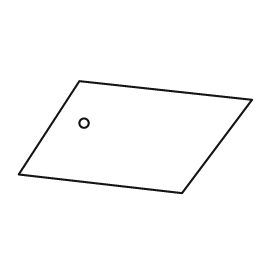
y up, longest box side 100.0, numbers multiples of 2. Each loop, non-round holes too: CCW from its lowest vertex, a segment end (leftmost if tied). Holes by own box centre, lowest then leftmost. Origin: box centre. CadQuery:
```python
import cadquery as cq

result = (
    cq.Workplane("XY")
    .moveTo(20.0, -24.0)
    .lineTo(50.0, 16.0)
    .lineTo(-24.0, 24.0)
    .lineTo(-50.0, -16.0)
    .close()
    .moveTo(-22.0, 6.0)
    .circle(2.0)
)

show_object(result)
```